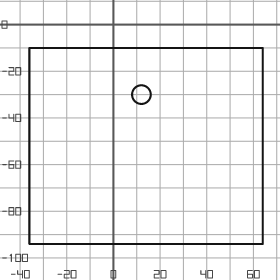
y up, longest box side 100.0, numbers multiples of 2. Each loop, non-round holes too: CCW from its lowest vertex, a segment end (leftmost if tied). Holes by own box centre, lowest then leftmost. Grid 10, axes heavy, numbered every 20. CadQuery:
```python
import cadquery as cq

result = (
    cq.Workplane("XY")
    .moveTo(-36.0, -94.0)
    .lineTo(64.0, -94.0)
    .lineTo(64.0, -10.0)
    .lineTo(-36.0, -10.0)
    .close()
    .moveTo(12.0, -30.0)
    .circle(4.0)
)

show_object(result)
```